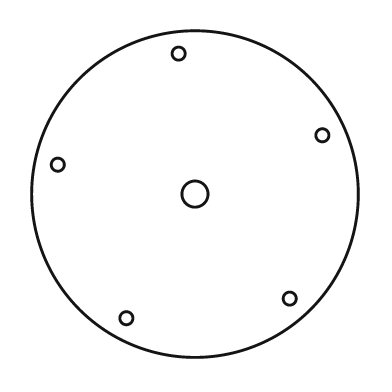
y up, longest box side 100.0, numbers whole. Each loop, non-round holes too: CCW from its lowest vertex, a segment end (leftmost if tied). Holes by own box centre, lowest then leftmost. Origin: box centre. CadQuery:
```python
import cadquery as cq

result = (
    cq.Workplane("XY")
    .moveTo(0.0, 0.0)
    .circle(50.0)
    .moveTo(-21.0, -38.0)
    .circle(2.0)
    .moveTo(29.0, -32.0)
    .circle(2.0)
    .moveTo(0.0, 0.0)
    .circle(4.0)
    .moveTo(-42.0, 9.0)
    .circle(2.0)
    .moveTo(39.0, 18.0)
    .circle(2.0)
    .moveTo(-5.0, 43.0)
    .circle(2.0)
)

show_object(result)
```